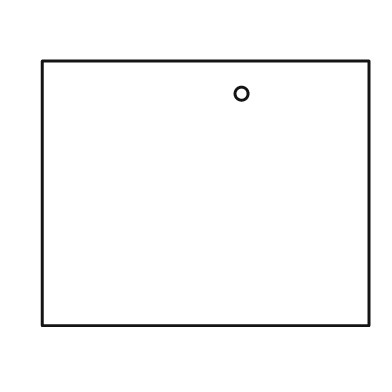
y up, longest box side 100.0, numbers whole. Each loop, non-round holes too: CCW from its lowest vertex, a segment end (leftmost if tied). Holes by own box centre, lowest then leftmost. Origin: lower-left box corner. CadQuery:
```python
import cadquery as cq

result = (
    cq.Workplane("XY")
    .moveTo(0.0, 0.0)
    .lineTo(100.0, 0.0)
    .lineTo(100.0, 81.0)
    .lineTo(0.0, 81.0)
    .close()
    .moveTo(61.0, 71.0)
    .circle(2.0)
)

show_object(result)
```